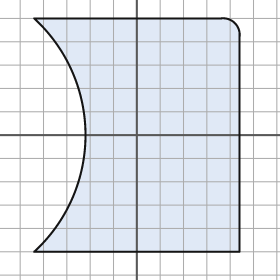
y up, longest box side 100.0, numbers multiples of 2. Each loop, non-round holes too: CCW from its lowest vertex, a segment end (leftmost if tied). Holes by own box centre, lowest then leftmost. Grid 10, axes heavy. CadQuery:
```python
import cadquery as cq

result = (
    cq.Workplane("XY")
    .moveTo(-44.0, -50.0)
    .lineTo(44.0, -50.0)
    .lineTo(44.0, 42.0)
    .threePointArc((42.0, 48.0), (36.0, 50.0))
    .lineTo(-44.0, 50.0)
    .threePointArc((-22.0, 0.0), (-44.0, -50.0))
    .close()
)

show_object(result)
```